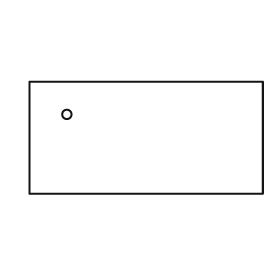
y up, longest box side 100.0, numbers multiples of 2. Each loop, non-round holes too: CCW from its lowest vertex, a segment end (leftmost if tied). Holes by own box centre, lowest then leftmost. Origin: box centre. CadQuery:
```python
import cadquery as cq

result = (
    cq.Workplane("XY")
    .moveTo(-50.0, -24.0)
    .lineTo(50.0, -24.0)
    .lineTo(50.0, 24.0)
    .lineTo(-50.0, 24.0)
    .close()
    .moveTo(-34.0, 10.0)
    .circle(2.0)
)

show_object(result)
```